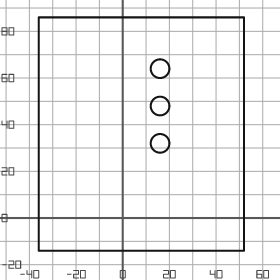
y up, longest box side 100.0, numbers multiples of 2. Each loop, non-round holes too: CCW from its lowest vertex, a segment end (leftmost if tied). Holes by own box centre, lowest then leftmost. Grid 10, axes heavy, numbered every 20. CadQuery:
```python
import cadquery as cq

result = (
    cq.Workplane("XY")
    .moveTo(-36.0, -14.0)
    .lineTo(52.0, -14.0)
    .lineTo(52.0, 86.0)
    .lineTo(-36.0, 86.0)
    .close()
    .moveTo(16.0, 32.0)
    .circle(4.0)
    .moveTo(16.0, 48.0)
    .circle(4.0)
    .moveTo(16.0, 64.0)
    .circle(4.0)
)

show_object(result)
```